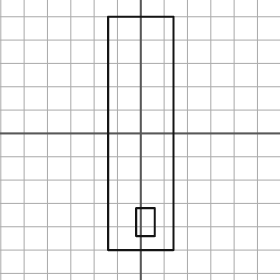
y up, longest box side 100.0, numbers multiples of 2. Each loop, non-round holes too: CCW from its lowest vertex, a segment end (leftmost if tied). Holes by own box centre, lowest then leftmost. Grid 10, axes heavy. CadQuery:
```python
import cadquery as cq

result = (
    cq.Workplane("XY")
    .moveTo(-14.0, -50.0)
    .lineTo(14.0, -50.0)
    .lineTo(14.0, 50.0)
    .lineTo(-14.0, 50.0)
    .close()
    .moveTo(-2.0, -44.0)
    .lineTo(6.0, -44.0)
    .lineTo(6.0, -32.0)
    .lineTo(-2.0, -32.0)
    .close()
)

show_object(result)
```